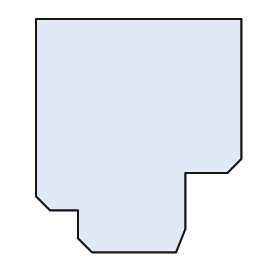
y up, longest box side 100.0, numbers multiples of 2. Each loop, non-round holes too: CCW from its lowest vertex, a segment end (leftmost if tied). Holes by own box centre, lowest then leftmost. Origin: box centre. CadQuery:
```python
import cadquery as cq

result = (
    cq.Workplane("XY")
    .moveTo(-20.0, -50.0)
    .lineTo(16.0, -50.0)
    .lineTo(20.0, -40.0)
    .lineTo(20.0, -16.0)
    .lineTo(38.0, -16.0)
    .lineTo(44.0, -10.0)
    .lineTo(44.0, 50.0)
    .lineTo(-44.0, 50.0)
    .lineTo(-44.0, -26.0)
    .lineTo(-38.0, -32.0)
    .lineTo(-26.0, -32.0)
    .lineTo(-26.0, -44.0)
    .close()
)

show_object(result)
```